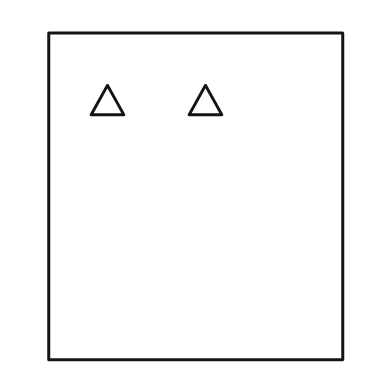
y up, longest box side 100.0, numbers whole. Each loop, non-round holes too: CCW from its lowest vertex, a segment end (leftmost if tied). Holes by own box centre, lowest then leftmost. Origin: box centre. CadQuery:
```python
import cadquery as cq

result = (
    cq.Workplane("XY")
    .moveTo(-45.0, -50.0)
    .lineTo(45.0, -50.0)
    .lineTo(45.0, 50.0)
    .lineTo(-45.0, 50.0)
    .close()
    .moveTo(-32.0, 25.0)
    .lineTo(-22.0, 25.0)
    .lineTo(-27.0, 34.0)
    .close()
    .moveTo(-2.0, 25.0)
    .lineTo(8.0, 25.0)
    .lineTo(3.0, 34.0)
    .close()
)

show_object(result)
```